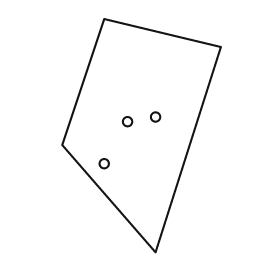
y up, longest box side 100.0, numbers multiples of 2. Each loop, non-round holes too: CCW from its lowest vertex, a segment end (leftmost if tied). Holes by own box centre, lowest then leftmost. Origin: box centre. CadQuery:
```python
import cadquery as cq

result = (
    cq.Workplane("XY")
    .moveTo(6.0, -50.0)
    .lineTo(34.0, 38.0)
    .lineTo(-16.0, 50.0)
    .lineTo(-34.0, -4.0)
    .close()
    .moveTo(-16.0, -12.0)
    .circle(2.0)
    .moveTo(-6.0, 6.0)
    .circle(2.0)
    .moveTo(6.0, 8.0)
    .circle(2.0)
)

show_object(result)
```